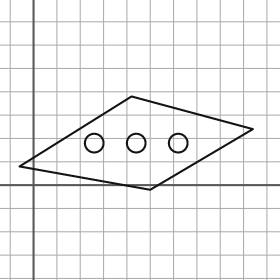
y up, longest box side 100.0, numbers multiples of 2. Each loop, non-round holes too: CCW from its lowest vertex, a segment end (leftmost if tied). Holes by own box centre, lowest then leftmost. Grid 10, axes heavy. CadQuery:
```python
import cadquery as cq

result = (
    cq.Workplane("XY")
    .moveTo(50.0, -2.0)
    .lineTo(94.0, 24.0)
    .lineTo(42.0, 38.0)
    .lineTo(-6.0, 8.0)
    .close()
    .moveTo(26.0, 18.0)
    .circle(4.0)
    .moveTo(44.0, 18.0)
    .circle(4.0)
    .moveTo(62.0, 18.0)
    .circle(4.0)
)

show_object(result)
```